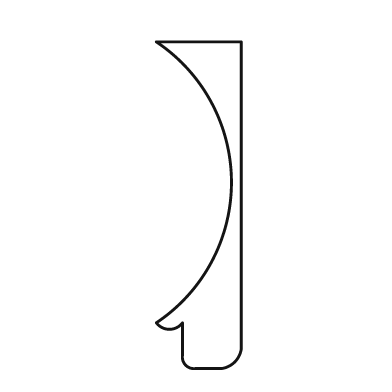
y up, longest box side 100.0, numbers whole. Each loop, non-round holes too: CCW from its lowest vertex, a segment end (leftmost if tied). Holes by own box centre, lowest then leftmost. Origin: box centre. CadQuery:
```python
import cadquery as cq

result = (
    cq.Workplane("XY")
    .moveTo(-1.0, -50.0)
    .lineTo(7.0, -50.0)
    .threePointArc((11.0, -48.0), (13.0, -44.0))
    .lineTo(13.0, 50.0)
    .lineTo(-13.0, 50.0)
    .threePointArc((10.0, 7.0), (-13.0, -36.0))
    .threePointArc((-9.0, -38.0), (-5.0, -36.0))
    .lineTo(-5.0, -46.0)
    .threePointArc((-4.0, -49.0), (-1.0, -50.0))
    .close()
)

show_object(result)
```